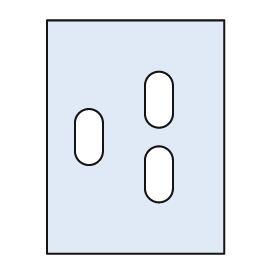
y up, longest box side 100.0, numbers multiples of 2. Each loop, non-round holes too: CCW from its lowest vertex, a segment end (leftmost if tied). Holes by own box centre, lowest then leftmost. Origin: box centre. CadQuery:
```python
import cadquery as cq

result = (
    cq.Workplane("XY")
    .moveTo(-38.0, -50.0)
    .lineTo(38.0, -50.0)
    .lineTo(38.0, 50.0)
    .lineTo(-38.0, 50.0)
    .close()
    .moveTo(4.0, -22.0)
    .threePointArc((10.0, -28.0), (16.0, -22.0))
    .lineTo(16.0, -10.0)
    .threePointArc((10.0, -4.0), (4.0, -10.0))
    .close()
    .moveTo(-26.0, -6.0)
    .threePointArc((-20.0, -12.0), (-14.0, -6.0))
    .lineTo(-14.0, 6.0)
    .threePointArc((-20.0, 12.0), (-26.0, 6.0))
    .close()
    .moveTo(4.0, 10.0)
    .threePointArc((10.0, 4.0), (16.0, 10.0))
    .lineTo(16.0, 22.0)
    .threePointArc((10.0, 28.0), (4.0, 22.0))
    .close()
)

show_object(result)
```